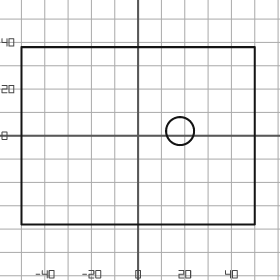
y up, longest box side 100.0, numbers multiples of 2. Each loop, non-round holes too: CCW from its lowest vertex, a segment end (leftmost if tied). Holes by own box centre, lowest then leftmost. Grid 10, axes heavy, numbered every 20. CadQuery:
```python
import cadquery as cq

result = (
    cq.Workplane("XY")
    .moveTo(-50.0, -38.0)
    .lineTo(50.0, -38.0)
    .lineTo(50.0, 38.0)
    .lineTo(-50.0, 38.0)
    .close()
    .moveTo(18.0, 2.0)
    .circle(6.0)
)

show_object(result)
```